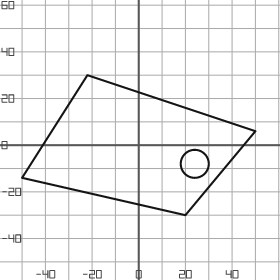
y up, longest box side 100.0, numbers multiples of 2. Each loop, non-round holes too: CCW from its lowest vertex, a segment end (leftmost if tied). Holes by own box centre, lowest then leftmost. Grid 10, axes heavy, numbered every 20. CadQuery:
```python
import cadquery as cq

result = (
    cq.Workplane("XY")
    .moveTo(20.0, -30.0)
    .lineTo(50.0, 6.0)
    .lineTo(-22.0, 30.0)
    .lineTo(-50.0, -14.0)
    .close()
    .moveTo(24.0, -8.0)
    .circle(6.0)
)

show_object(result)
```